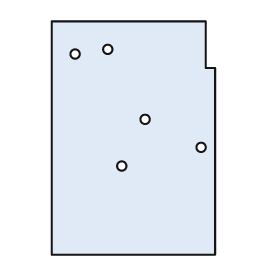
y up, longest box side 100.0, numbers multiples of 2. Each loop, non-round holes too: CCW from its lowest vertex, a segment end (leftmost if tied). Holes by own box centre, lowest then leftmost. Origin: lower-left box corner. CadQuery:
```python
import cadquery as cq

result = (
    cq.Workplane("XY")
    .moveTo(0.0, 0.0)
    .lineTo(70.0, 0.0)
    .lineTo(70.0, 80.0)
    .lineTo(66.0, 80.0)
    .lineTo(66.0, 100.0)
    .lineTo(0.0, 100.0)
    .close()
    .moveTo(30.0, 38.0)
    .circle(2.0)
    .moveTo(64.0, 46.0)
    .circle(2.0)
    .moveTo(40.0, 58.0)
    .circle(2.0)
    .moveTo(10.0, 86.0)
    .circle(2.0)
    .moveTo(24.0, 88.0)
    .circle(2.0)
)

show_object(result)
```